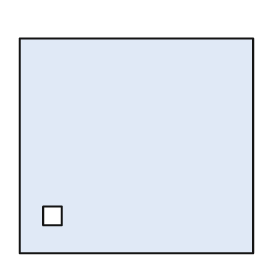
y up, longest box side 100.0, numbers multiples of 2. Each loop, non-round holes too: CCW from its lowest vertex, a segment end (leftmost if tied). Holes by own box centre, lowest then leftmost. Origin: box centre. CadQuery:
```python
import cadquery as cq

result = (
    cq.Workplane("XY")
    .moveTo(-50.0, -46.0)
    .lineTo(50.0, -46.0)
    .lineTo(50.0, 46.0)
    .lineTo(-50.0, 46.0)
    .close()
    .moveTo(-40.0, -34.0)
    .lineTo(-32.0, -34.0)
    .lineTo(-32.0, -26.0)
    .lineTo(-40.0, -26.0)
    .close()
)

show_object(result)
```